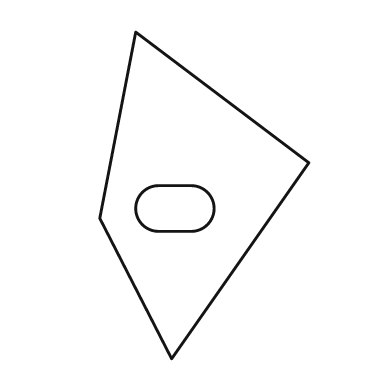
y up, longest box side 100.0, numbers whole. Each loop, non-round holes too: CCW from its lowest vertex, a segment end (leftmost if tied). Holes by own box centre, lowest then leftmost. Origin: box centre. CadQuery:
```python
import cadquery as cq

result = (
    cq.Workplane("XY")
    .moveTo(-10.0, -50.0)
    .lineTo(32.0, 10.0)
    .lineTo(-21.0, 50.0)
    .lineTo(-32.0, -7.0)
    .close()
    .moveTo(-14.0, -11.0)
    .lineTo(-4.0, -11.0)
    .threePointArc((3.0, -4.0), (-4.0, 3.0))
    .lineTo(-14.0, 3.0)
    .threePointArc((-21.0, -4.0), (-14.0, -11.0))
    .close()
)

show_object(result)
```